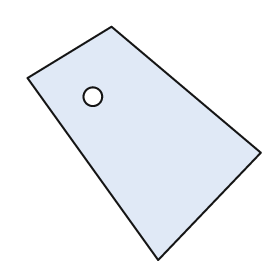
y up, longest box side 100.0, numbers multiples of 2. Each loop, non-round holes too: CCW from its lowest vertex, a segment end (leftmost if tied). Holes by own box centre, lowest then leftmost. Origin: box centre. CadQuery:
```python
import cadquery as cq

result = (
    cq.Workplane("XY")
    .moveTo(6.0, -50.0)
    .lineTo(50.0, -4.0)
    .lineTo(-14.0, 50.0)
    .lineTo(-50.0, 28.0)
    .close()
    .moveTo(-22.0, 20.0)
    .circle(4.0)
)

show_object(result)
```